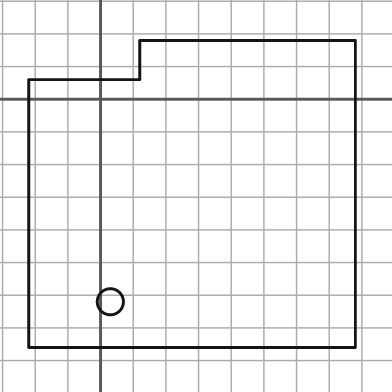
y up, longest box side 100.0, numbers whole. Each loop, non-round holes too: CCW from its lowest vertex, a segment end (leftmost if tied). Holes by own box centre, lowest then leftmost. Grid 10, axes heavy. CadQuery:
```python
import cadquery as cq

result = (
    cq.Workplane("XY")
    .moveTo(-22.0, -76.0)
    .lineTo(78.0, -76.0)
    .lineTo(78.0, 18.0)
    .lineTo(12.0, 18.0)
    .lineTo(12.0, 6.0)
    .lineTo(-22.0, 6.0)
    .close()
    .moveTo(3.0, -62.0)
    .circle(4.0)
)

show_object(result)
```